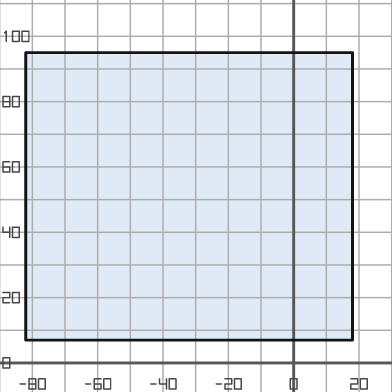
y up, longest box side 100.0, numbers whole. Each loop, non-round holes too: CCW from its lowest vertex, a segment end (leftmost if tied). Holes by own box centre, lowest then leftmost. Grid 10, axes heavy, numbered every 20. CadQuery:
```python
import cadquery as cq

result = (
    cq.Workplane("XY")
    .moveTo(-82.0, 7.0)
    .lineTo(18.0, 7.0)
    .lineTo(18.0, 95.0)
    .lineTo(-82.0, 95.0)
    .close()
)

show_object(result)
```